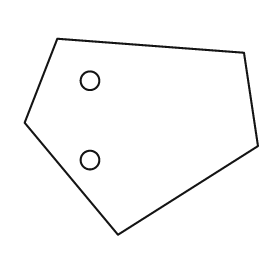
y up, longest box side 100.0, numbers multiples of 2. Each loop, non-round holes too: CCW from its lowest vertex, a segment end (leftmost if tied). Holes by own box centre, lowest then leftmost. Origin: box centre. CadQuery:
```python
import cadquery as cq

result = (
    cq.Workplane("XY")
    .moveTo(-10.0, -42.0)
    .lineTo(50.0, -4.0)
    .lineTo(44.0, 36.0)
    .lineTo(-36.0, 42.0)
    .lineTo(-50.0, 6.0)
    .close()
    .moveTo(-22.0, -10.0)
    .circle(4.0)
    .moveTo(-22.0, 24.0)
    .circle(4.0)
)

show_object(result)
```